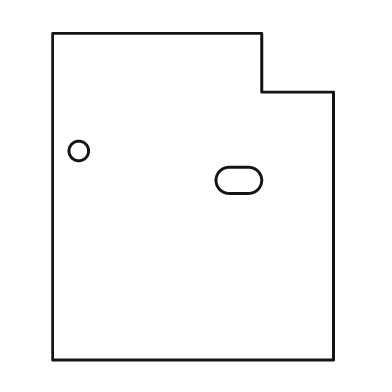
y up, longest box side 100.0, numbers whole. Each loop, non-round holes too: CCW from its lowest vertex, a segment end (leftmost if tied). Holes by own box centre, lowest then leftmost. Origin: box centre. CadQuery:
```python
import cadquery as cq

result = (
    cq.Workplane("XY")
    .moveTo(-43.0, -50.0)
    .lineTo(43.0, -50.0)
    .lineTo(43.0, 32.0)
    .lineTo(21.0, 32.0)
    .lineTo(21.0, 50.0)
    .lineTo(-43.0, 50.0)
    .close()
    .moveTo(11.0, 1.0)
    .lineTo(17.0, 1.0)
    .threePointArc((21.0, 5.0), (17.0, 9.0))
    .lineTo(11.0, 9.0)
    .threePointArc((7.0, 5.0), (11.0, 1.0))
    .close()
    .moveTo(-35.0, 14.0)
    .circle(3.0)
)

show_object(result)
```